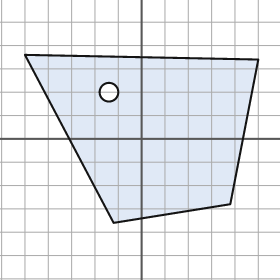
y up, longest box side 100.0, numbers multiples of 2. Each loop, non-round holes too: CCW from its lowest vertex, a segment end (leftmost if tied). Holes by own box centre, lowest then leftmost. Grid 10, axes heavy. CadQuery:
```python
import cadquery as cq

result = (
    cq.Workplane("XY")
    .moveTo(-12.0, -36.0)
    .lineTo(38.0, -28.0)
    .lineTo(50.0, 34.0)
    .lineTo(-50.0, 36.0)
    .close()
    .moveTo(-14.0, 20.0)
    .circle(4.0)
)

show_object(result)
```